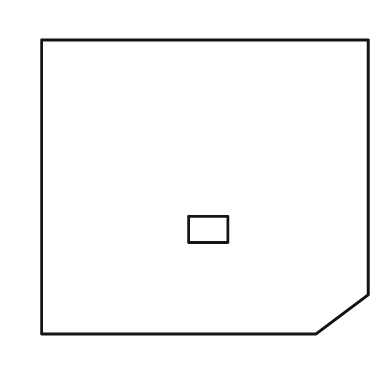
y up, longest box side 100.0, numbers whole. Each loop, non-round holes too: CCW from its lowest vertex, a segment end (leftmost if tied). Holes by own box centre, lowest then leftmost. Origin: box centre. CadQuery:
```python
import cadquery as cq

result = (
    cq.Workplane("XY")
    .moveTo(-50.0, -45.0)
    .lineTo(34.0, -45.0)
    .lineTo(50.0, -33.0)
    .lineTo(50.0, 45.0)
    .lineTo(-50.0, 45.0)
    .close()
    .moveTo(-5.0, -17.0)
    .lineTo(7.0, -17.0)
    .lineTo(7.0, -9.0)
    .lineTo(-5.0, -9.0)
    .close()
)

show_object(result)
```